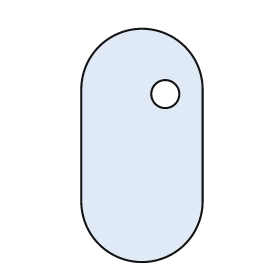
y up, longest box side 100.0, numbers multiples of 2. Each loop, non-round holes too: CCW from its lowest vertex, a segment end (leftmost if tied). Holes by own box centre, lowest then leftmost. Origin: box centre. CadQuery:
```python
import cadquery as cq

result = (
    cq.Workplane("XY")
    .moveTo(-26.0, -24.0)
    .threePointArc((0.0, -50.0), (26.0, -24.0))
    .lineTo(26.0, 24.0)
    .threePointArc((0.0, 50.0), (-26.0, 24.0))
    .close()
    .moveTo(10.0, 22.0)
    .circle(6.0)
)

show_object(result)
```